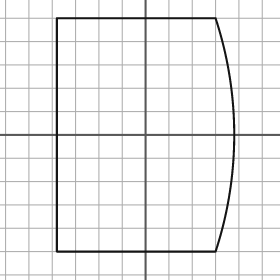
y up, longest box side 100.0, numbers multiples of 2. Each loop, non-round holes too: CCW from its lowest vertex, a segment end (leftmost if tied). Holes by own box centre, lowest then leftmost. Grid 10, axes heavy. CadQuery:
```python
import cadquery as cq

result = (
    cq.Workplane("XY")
    .moveTo(-38.0, -50.0)
    .lineTo(30.0, -50.0)
    .threePointArc((38.0, 0.0), (30.0, 50.0))
    .lineTo(-38.0, 50.0)
    .close()
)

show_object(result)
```